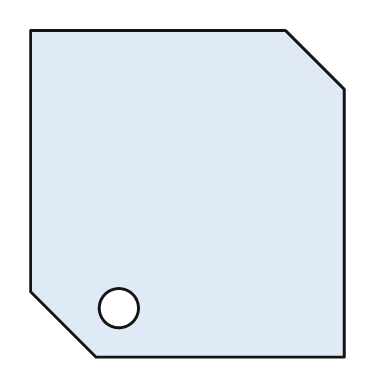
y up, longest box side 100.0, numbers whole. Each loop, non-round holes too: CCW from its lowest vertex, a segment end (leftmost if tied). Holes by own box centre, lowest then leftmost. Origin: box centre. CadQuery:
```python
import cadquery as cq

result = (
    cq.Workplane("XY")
    .moveTo(-28.0, -50.0)
    .lineTo(48.0, -50.0)
    .lineTo(48.0, 32.0)
    .lineTo(30.0, 50.0)
    .lineTo(-48.0, 50.0)
    .lineTo(-48.0, -30.0)
    .close()
    .moveTo(-21.0, -35.0)
    .circle(6.0)
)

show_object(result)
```